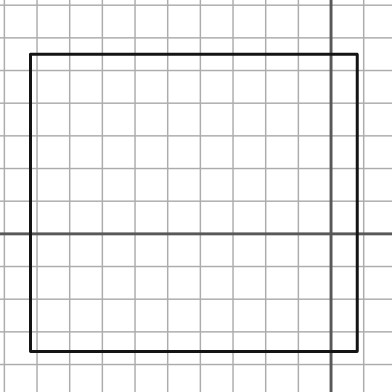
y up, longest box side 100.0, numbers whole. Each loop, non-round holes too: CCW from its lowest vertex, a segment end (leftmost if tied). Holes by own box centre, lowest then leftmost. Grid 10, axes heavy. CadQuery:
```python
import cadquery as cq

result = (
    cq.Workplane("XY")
    .moveTo(-92.0, -36.0)
    .lineTo(8.0, -36.0)
    .lineTo(8.0, 55.0)
    .lineTo(-92.0, 55.0)
    .close()
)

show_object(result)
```